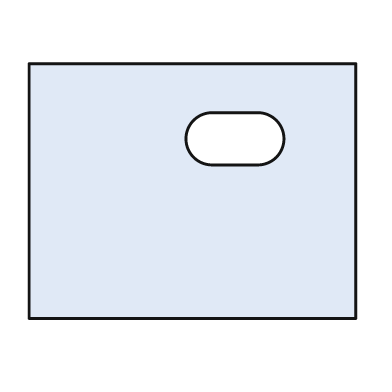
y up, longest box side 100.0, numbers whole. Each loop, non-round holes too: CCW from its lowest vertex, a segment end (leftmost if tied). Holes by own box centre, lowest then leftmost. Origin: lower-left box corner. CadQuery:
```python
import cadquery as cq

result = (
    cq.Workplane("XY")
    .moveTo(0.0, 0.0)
    .lineTo(100.0, 0.0)
    .lineTo(100.0, 78.0)
    .lineTo(0.0, 78.0)
    .close()
    .moveTo(56.0, 47.0)
    .lineTo(70.0, 47.0)
    .threePointArc((78.0, 55.0), (70.0, 63.0))
    .lineTo(56.0, 63.0)
    .threePointArc((48.0, 55.0), (56.0, 47.0))
    .close()
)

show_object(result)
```